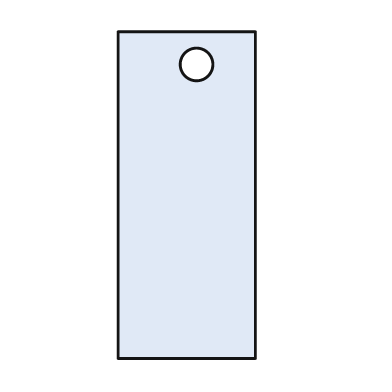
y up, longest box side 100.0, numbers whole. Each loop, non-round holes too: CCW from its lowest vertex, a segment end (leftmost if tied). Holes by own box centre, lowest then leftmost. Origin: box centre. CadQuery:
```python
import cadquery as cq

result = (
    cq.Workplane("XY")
    .moveTo(-21.0, -50.0)
    .lineTo(21.0, -50.0)
    .lineTo(21.0, 50.0)
    .lineTo(-21.0, 50.0)
    .close()
    .moveTo(3.0, 40.0)
    .circle(5.0)
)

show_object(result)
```